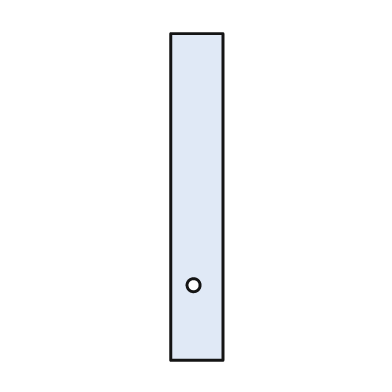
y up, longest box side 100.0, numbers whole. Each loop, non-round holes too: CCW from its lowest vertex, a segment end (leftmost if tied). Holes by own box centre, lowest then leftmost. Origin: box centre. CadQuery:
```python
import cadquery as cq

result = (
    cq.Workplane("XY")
    .moveTo(-8.0, -50.0)
    .lineTo(8.0, -50.0)
    .lineTo(8.0, 50.0)
    .lineTo(-8.0, 50.0)
    .close()
    .moveTo(-1.0, -27.0)
    .circle(2.0)
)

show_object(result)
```